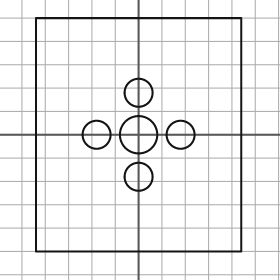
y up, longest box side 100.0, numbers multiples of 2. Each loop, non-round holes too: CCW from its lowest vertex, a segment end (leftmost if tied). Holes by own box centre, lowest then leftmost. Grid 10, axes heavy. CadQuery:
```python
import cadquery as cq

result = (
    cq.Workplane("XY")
    .moveTo(-44.0, -50.0)
    .lineTo(44.0, -50.0)
    .lineTo(44.0, 50.0)
    .lineTo(-44.0, 50.0)
    .close()
    .moveTo(0.0, -18.0)
    .circle(6.0)
    .moveTo(-18.0, 0.0)
    .circle(6.0)
    .moveTo(0.0, 0.0)
    .circle(8.0)
    .moveTo(18.0, 0.0)
    .circle(6.0)
    .moveTo(0.0, 18.0)
    .circle(6.0)
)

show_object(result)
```